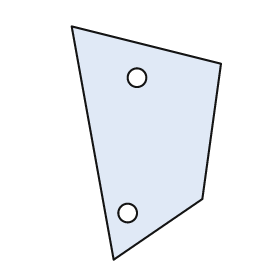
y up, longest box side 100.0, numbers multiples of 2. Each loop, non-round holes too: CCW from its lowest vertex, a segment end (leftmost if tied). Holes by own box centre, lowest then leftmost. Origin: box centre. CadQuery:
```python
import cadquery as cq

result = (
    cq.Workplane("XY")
    .moveTo(-14.0, -50.0)
    .lineTo(24.0, -24.0)
    .lineTo(32.0, 34.0)
    .lineTo(-32.0, 50.0)
    .close()
    .moveTo(-8.0, -30.0)
    .circle(4.0)
    .moveTo(-4.0, 28.0)
    .circle(4.0)
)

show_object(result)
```